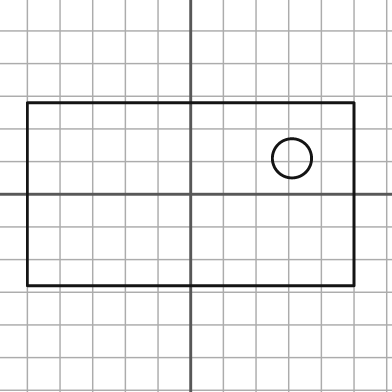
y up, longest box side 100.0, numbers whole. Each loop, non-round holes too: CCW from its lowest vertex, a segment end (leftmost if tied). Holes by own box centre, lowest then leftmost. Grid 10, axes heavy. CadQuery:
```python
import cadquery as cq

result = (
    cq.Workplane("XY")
    .moveTo(-50.0, -28.0)
    .lineTo(50.0, -28.0)
    .lineTo(50.0, 28.0)
    .lineTo(-50.0, 28.0)
    .close()
    .moveTo(31.0, 11.0)
    .circle(6.0)
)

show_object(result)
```